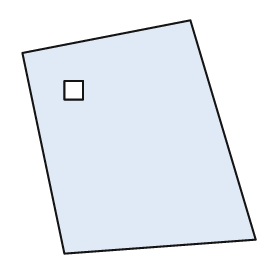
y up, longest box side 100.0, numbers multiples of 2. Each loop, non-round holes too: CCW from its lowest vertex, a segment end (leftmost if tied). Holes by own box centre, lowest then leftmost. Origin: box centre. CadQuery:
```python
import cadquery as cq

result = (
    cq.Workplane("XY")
    .moveTo(-32.0, -50.0)
    .lineTo(50.0, -44.0)
    .lineTo(22.0, 50.0)
    .lineTo(-50.0, 36.0)
    .close()
    .moveTo(-32.0, 16.0)
    .lineTo(-24.0, 16.0)
    .lineTo(-24.0, 24.0)
    .lineTo(-32.0, 24.0)
    .close()
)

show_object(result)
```